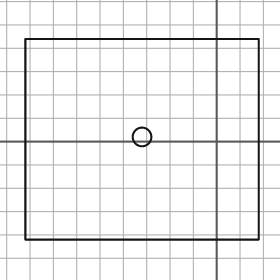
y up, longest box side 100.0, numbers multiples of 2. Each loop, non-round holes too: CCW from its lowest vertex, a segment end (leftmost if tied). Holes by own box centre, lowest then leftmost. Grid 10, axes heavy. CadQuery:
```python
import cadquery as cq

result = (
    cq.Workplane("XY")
    .moveTo(-82.0, -42.0)
    .lineTo(18.0, -42.0)
    .lineTo(18.0, 44.0)
    .lineTo(-82.0, 44.0)
    .close()
    .moveTo(-32.0, 2.0)
    .circle(4.0)
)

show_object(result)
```